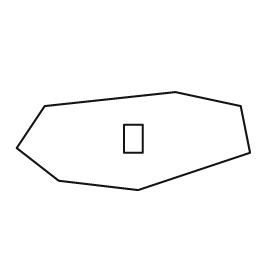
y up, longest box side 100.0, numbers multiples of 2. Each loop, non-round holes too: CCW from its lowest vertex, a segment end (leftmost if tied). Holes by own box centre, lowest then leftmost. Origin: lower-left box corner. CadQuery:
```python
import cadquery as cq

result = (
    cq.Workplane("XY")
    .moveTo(52.0, 0.0)
    .lineTo(100.0, 16.0)
    .lineTo(96.0, 36.0)
    .lineTo(68.0, 42.0)
    .lineTo(12.0, 36.0)
    .lineTo(0.0, 18.0)
    .lineTo(18.0, 4.0)
    .close()
    .moveTo(46.0, 16.0)
    .lineTo(54.0, 16.0)
    .lineTo(54.0, 28.0)
    .lineTo(46.0, 28.0)
    .close()
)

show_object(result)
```